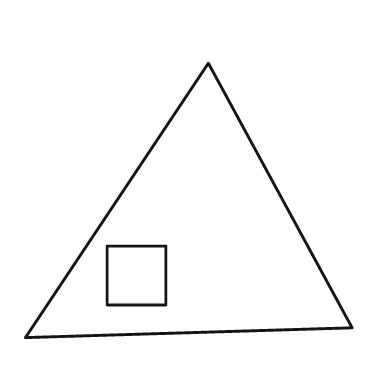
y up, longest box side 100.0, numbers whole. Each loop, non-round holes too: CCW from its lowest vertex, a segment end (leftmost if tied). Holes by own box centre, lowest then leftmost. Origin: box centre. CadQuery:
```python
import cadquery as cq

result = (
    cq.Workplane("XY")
    .moveTo(-50.0, -42.0)
    .lineTo(50.0, -39.0)
    .lineTo(6.0, 42.0)
    .close()
    .moveTo(-25.0, -32.0)
    .lineTo(-7.0, -32.0)
    .lineTo(-7.0, -14.0)
    .lineTo(-25.0, -14.0)
    .close()
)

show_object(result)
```